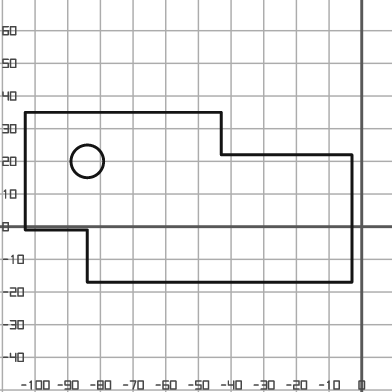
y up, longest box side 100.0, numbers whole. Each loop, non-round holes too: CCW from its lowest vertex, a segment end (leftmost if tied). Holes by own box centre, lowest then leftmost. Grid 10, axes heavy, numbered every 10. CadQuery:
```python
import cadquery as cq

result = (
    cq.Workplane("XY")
    .moveTo(-84.0, -17.0)
    .lineTo(-3.0, -17.0)
    .lineTo(-3.0, 22.0)
    .lineTo(-43.0, 22.0)
    .lineTo(-43.0, 35.0)
    .lineTo(-103.0, 35.0)
    .lineTo(-103.0, -1.0)
    .lineTo(-84.0, -1.0)
    .close()
    .moveTo(-84.0, 20.0)
    .circle(5.0)
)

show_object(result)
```